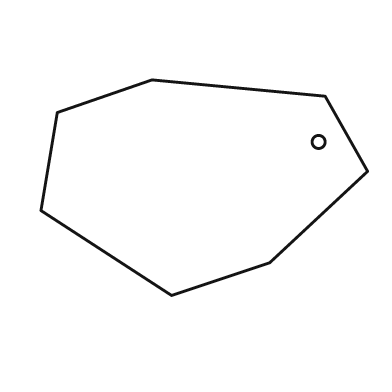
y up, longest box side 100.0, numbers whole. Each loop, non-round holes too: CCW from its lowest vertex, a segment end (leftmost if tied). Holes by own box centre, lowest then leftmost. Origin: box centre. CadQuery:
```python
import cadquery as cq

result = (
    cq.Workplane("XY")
    .moveTo(-10.0, -33.0)
    .lineTo(20.0, -23.0)
    .lineTo(50.0, 5.0)
    .lineTo(37.0, 28.0)
    .lineTo(-16.0, 33.0)
    .lineTo(-45.0, 23.0)
    .lineTo(-50.0, -7.0)
    .close()
    .moveTo(35.0, 14.0)
    .circle(2.0)
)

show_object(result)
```